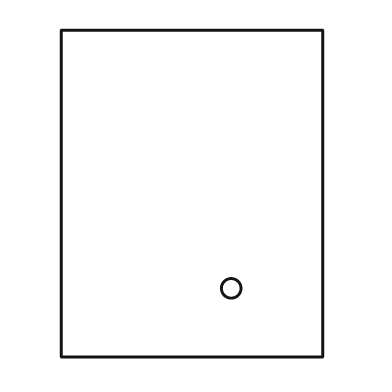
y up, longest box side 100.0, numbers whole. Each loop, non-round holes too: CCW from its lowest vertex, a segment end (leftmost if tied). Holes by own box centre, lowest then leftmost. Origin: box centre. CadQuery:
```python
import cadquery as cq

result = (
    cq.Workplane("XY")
    .moveTo(-40.0, -50.0)
    .lineTo(40.0, -50.0)
    .lineTo(40.0, 50.0)
    .lineTo(-40.0, 50.0)
    .close()
    .moveTo(12.0, -29.0)
    .circle(3.0)
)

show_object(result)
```